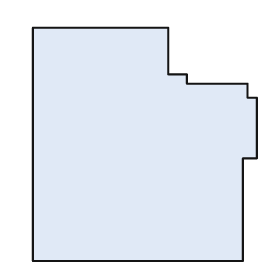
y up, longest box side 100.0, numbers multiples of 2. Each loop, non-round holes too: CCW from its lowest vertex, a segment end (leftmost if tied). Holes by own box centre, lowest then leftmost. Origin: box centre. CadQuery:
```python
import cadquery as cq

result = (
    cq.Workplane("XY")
    .moveTo(-48.0, -50.0)
    .lineTo(42.0, -50.0)
    .lineTo(42.0, -6.0)
    .lineTo(48.0, -6.0)
    .lineTo(48.0, 20.0)
    .lineTo(44.0, 20.0)
    .lineTo(44.0, 26.0)
    .lineTo(18.0, 26.0)
    .lineTo(18.0, 30.0)
    .lineTo(10.0, 30.0)
    .lineTo(10.0, 50.0)
    .lineTo(-48.0, 50.0)
    .close()
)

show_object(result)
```